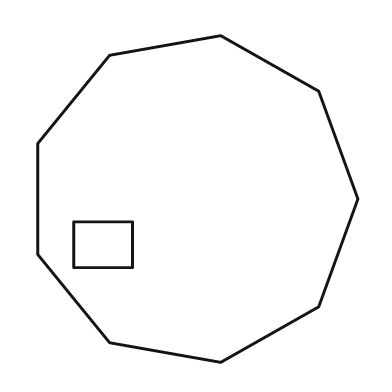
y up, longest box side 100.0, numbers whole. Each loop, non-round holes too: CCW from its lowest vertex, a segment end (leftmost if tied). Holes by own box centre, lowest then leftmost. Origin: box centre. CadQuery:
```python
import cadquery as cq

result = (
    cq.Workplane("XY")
    .moveTo(7.0, -50.0)
    .lineTo(37.0, -33.0)
    .lineTo(49.0, 0.0)
    .lineTo(37.0, 33.0)
    .lineTo(7.0, 50.0)
    .lineTo(-27.0, 44.0)
    .lineTo(-49.0, 17.0)
    .lineTo(-49.0, -17.0)
    .lineTo(-27.0, -44.0)
    .close()
    .moveTo(-38.0, -21.0)
    .lineTo(-20.0, -21.0)
    .lineTo(-20.0, -7.0)
    .lineTo(-38.0, -7.0)
    .close()
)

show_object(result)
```